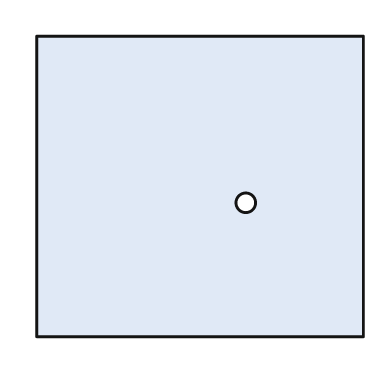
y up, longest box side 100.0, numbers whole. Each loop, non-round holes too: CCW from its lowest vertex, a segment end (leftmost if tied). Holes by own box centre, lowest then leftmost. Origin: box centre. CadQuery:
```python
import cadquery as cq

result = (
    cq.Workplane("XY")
    .moveTo(-50.0, -46.0)
    .lineTo(50.0, -46.0)
    .lineTo(50.0, 46.0)
    .lineTo(-50.0, 46.0)
    .close()
    .moveTo(14.0, -5.0)
    .circle(3.0)
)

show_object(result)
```